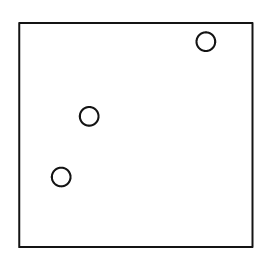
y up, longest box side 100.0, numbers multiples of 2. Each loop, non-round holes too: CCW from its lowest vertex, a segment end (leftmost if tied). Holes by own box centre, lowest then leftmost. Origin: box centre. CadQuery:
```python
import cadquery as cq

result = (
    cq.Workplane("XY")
    .moveTo(-50.0, -48.0)
    .lineTo(50.0, -48.0)
    .lineTo(50.0, 48.0)
    .lineTo(-50.0, 48.0)
    .close()
    .moveTo(-32.0, -18.0)
    .circle(4.0)
    .moveTo(-20.0, 8.0)
    .circle(4.0)
    .moveTo(30.0, 40.0)
    .circle(4.0)
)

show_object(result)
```